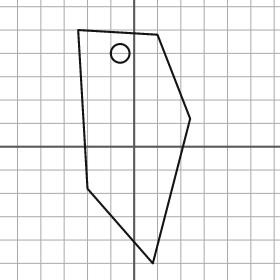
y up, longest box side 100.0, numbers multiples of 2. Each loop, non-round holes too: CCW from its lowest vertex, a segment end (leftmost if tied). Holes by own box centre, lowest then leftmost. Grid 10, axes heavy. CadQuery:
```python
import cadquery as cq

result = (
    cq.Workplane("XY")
    .moveTo(8.0, -50.0)
    .lineTo(24.0, 12.0)
    .lineTo(10.0, 48.0)
    .lineTo(-24.0, 50.0)
    .lineTo(-20.0, -18.0)
    .close()
    .moveTo(-6.0, 40.0)
    .circle(4.0)
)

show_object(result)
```